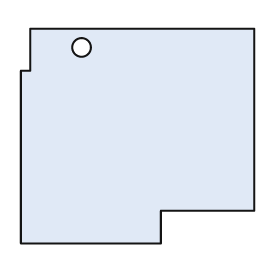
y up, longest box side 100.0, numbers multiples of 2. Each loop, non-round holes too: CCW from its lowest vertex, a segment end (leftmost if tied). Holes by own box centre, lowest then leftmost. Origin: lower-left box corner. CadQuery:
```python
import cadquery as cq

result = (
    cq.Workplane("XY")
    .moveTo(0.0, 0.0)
    .lineTo(60.0, 0.0)
    .lineTo(60.0, 14.0)
    .lineTo(100.0, 14.0)
    .lineTo(100.0, 92.0)
    .lineTo(4.0, 92.0)
    .lineTo(4.0, 74.0)
    .lineTo(0.0, 74.0)
    .close()
    .moveTo(26.0, 84.0)
    .circle(4.0)
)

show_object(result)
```